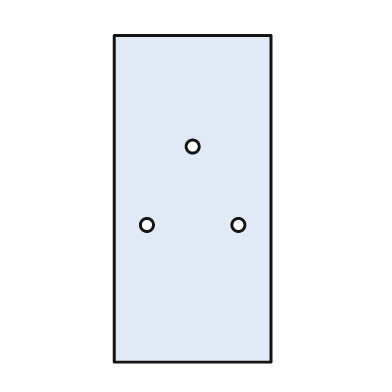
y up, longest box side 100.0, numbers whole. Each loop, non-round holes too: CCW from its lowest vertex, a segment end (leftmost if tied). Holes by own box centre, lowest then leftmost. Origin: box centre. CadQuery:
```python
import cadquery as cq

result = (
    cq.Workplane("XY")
    .moveTo(-24.0, -50.0)
    .lineTo(24.0, -50.0)
    .lineTo(24.0, 50.0)
    .lineTo(-24.0, 50.0)
    .close()
    .moveTo(-14.0, -8.0)
    .circle(2.0)
    .moveTo(14.0, -8.0)
    .circle(2.0)
    .moveTo(0.0, 16.0)
    .circle(2.0)
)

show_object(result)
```